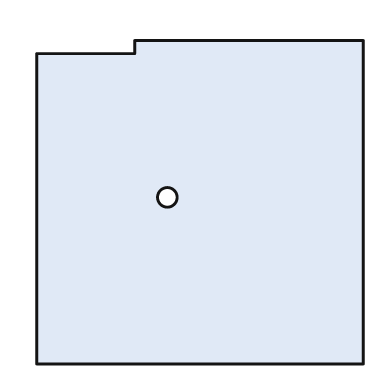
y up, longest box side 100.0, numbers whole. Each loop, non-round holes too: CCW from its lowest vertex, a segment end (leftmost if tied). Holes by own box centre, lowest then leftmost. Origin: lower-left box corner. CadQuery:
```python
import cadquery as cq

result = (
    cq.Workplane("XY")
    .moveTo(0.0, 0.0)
    .lineTo(100.0, 0.0)
    .lineTo(100.0, 99.0)
    .lineTo(30.0, 99.0)
    .lineTo(30.0, 95.0)
    .lineTo(0.0, 95.0)
    .close()
    .moveTo(40.0, 51.0)
    .circle(3.0)
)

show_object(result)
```